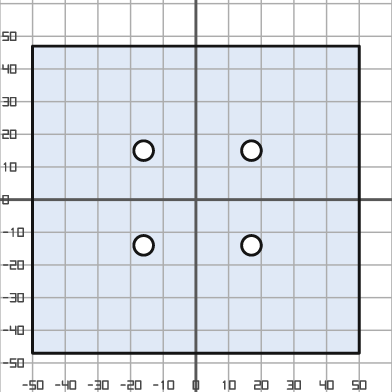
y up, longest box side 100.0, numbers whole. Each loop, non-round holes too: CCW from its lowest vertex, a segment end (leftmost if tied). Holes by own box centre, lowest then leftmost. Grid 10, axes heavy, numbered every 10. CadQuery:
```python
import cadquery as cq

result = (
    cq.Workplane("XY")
    .moveTo(-50.0, -47.0)
    .lineTo(50.0, -47.0)
    .lineTo(50.0, 47.0)
    .lineTo(-50.0, 47.0)
    .close()
    .moveTo(-16.0, -14.0)
    .circle(3.0)
    .moveTo(17.0, -14.0)
    .circle(3.0)
    .moveTo(-16.0, 15.0)
    .circle(3.0)
    .moveTo(17.0, 15.0)
    .circle(3.0)
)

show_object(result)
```